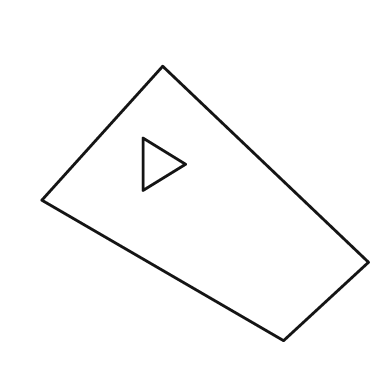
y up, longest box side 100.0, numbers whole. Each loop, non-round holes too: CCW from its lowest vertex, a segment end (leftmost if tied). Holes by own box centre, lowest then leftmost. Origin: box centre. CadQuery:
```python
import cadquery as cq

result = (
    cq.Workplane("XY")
    .moveTo(24.0, -42.0)
    .lineTo(50.0, -18.0)
    .lineTo(-13.0, 42.0)
    .lineTo(-50.0, 1.0)
    .close()
    .moveTo(-19.0, 4.0)
    .lineTo(-6.0, 12.0)
    .lineTo(-19.0, 20.0)
    .close()
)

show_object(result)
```